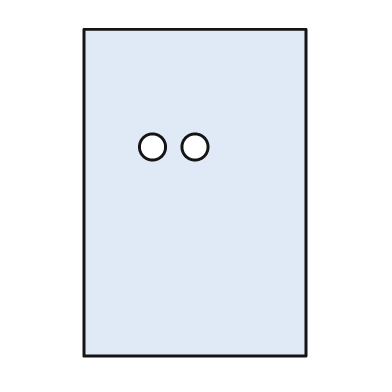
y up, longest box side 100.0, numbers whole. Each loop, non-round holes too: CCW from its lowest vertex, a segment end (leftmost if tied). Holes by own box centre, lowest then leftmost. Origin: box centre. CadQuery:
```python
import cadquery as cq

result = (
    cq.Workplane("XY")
    .moveTo(-34.0, -50.0)
    .lineTo(34.0, -50.0)
    .lineTo(34.0, 50.0)
    .lineTo(-34.0, 50.0)
    .close()
    .moveTo(-13.0, 14.0)
    .circle(4.0)
    .moveTo(0.0, 14.0)
    .circle(4.0)
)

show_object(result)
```